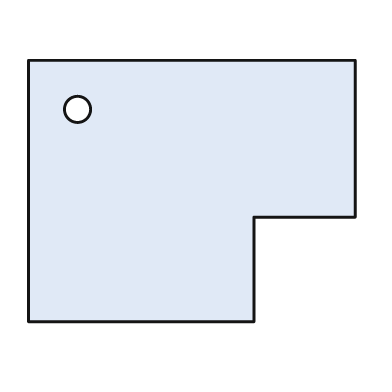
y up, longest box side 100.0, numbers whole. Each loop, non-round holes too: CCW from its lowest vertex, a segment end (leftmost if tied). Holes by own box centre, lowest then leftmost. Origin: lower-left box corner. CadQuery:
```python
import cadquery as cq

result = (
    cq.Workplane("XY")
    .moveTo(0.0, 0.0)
    .lineTo(69.0, 0.0)
    .lineTo(69.0, 32.0)
    .lineTo(100.0, 32.0)
    .lineTo(100.0, 80.0)
    .lineTo(0.0, 80.0)
    .close()
    .moveTo(15.0, 65.0)
    .circle(4.0)
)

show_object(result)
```